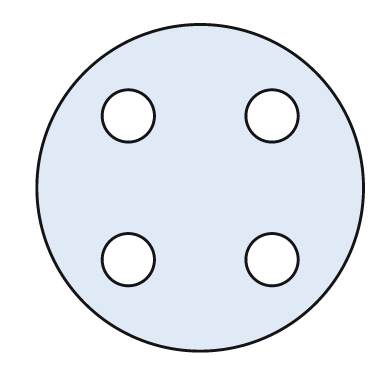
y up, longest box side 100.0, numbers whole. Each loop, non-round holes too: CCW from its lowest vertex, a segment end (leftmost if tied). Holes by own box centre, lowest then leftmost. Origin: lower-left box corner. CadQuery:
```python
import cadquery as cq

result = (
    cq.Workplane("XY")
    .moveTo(50.0, 50.0)
    .circle(50.0)
    .moveTo(28.0, 28.0)
    .circle(8.0)
    .moveTo(72.0, 28.0)
    .circle(8.0)
    .moveTo(28.0, 72.0)
    .circle(8.0)
    .moveTo(72.0, 72.0)
    .circle(8.0)
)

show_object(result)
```